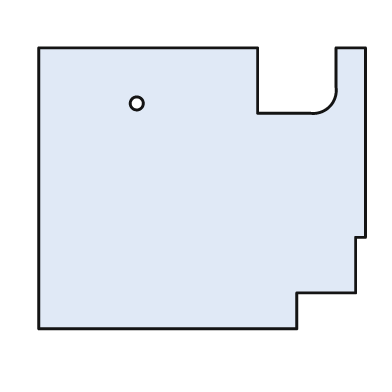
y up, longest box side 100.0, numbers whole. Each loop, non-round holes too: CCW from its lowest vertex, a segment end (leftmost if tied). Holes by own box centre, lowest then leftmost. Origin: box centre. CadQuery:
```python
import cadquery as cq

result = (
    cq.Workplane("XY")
    .moveTo(-50.0, -43.0)
    .lineTo(29.0, -43.0)
    .lineTo(29.0, -32.0)
    .lineTo(47.0, -32.0)
    .lineTo(47.0, -15.0)
    .lineTo(50.0, -15.0)
    .lineTo(50.0, 43.0)
    .lineTo(41.0, 43.0)
    .lineTo(41.0, 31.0)
    .threePointArc((39.0, 25.0), (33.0, 23.0))
    .lineTo(17.0, 23.0)
    .lineTo(17.0, 43.0)
    .lineTo(-50.0, 43.0)
    .close()
    .moveTo(-20.0, 26.0)
    .circle(2.0)
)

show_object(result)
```